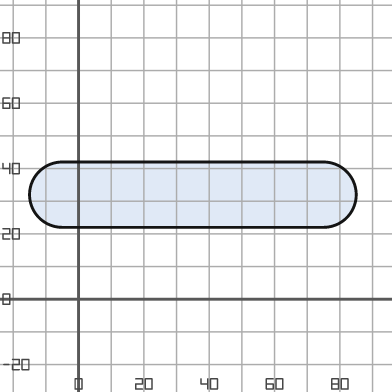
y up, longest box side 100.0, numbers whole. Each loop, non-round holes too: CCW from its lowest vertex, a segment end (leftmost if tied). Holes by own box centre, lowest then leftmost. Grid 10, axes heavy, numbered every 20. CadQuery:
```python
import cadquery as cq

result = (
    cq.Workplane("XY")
    .moveTo(-5.0, 22.0)
    .lineTo(75.0, 22.0)
    .threePointArc((85.0, 32.0), (75.0, 42.0))
    .lineTo(-5.0, 42.0)
    .threePointArc((-15.0, 32.0), (-5.0, 22.0))
    .close()
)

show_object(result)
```